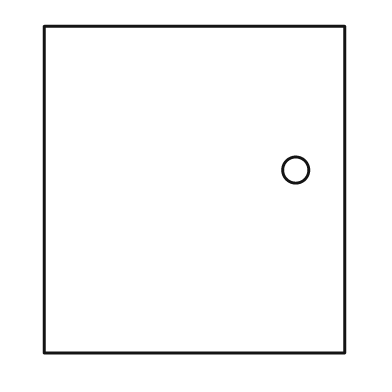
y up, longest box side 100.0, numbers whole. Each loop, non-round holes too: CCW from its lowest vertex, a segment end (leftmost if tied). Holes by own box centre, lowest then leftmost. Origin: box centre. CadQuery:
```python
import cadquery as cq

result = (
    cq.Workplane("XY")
    .moveTo(-46.0, -50.0)
    .lineTo(46.0, -50.0)
    .lineTo(46.0, 50.0)
    .lineTo(-46.0, 50.0)
    .close()
    .moveTo(31.0, 6.0)
    .circle(4.0)
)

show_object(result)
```